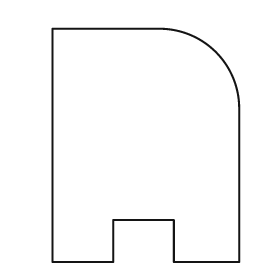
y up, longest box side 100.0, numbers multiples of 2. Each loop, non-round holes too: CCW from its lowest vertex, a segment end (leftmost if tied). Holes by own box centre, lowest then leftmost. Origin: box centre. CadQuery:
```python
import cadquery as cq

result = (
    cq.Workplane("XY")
    .moveTo(-40.0, -50.0)
    .lineTo(-14.0, -50.0)
    .lineTo(-14.0, -32.0)
    .lineTo(12.0, -32.0)
    .lineTo(12.0, -50.0)
    .lineTo(40.0, -50.0)
    .lineTo(40.0, 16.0)
    .threePointArc((30.0, 40.0), (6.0, 50.0))
    .lineTo(-40.0, 50.0)
    .close()
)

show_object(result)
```